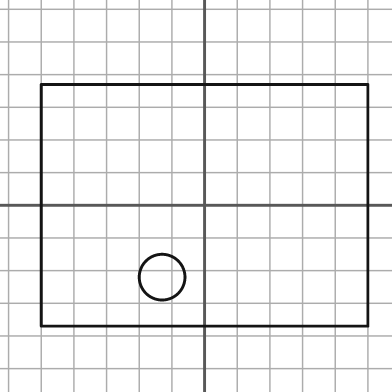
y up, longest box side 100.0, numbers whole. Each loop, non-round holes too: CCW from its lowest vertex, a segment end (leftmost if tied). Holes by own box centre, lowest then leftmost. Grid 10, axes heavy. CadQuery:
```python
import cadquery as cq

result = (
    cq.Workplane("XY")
    .moveTo(-50.0, -37.0)
    .lineTo(50.0, -37.0)
    .lineTo(50.0, 37.0)
    .lineTo(-50.0, 37.0)
    .close()
    .moveTo(-13.0, -22.0)
    .circle(7.0)
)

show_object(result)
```